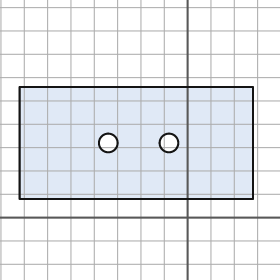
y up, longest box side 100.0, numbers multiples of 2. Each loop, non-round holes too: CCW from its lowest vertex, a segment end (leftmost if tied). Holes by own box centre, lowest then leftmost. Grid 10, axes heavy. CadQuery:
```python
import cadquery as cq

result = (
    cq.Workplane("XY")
    .moveTo(-72.0, 8.0)
    .lineTo(28.0, 8.0)
    .lineTo(28.0, 56.0)
    .lineTo(-72.0, 56.0)
    .close()
    .moveTo(-34.0, 32.0)
    .circle(4.0)
    .moveTo(-8.0, 32.0)
    .circle(4.0)
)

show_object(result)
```